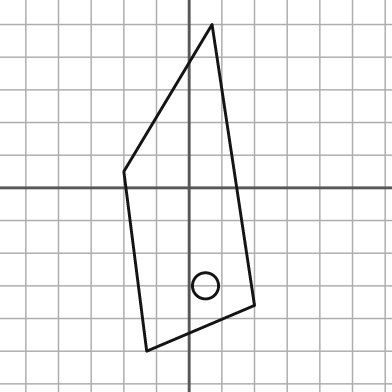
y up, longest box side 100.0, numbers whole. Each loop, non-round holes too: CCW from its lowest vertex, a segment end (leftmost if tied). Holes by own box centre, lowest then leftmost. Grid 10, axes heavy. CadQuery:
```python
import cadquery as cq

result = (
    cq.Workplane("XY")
    .moveTo(-13.0, -50.0)
    .lineTo(20.0, -36.0)
    .lineTo(7.0, 50.0)
    .lineTo(-20.0, 5.0)
    .close()
    .moveTo(5.0, -30.0)
    .circle(4.0)
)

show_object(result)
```